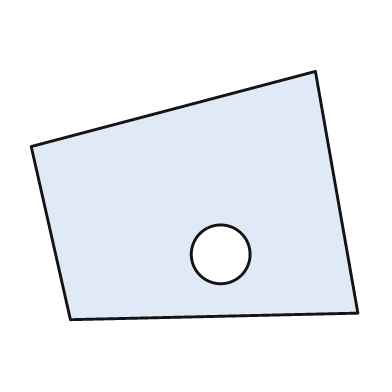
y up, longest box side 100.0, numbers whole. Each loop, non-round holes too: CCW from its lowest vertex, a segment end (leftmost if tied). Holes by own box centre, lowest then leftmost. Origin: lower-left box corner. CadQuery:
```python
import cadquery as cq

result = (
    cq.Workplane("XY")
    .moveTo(12.0, 0.0)
    .lineTo(100.0, 2.0)
    .lineTo(87.0, 76.0)
    .lineTo(0.0, 53.0)
    .close()
    .moveTo(58.0, 20.0)
    .circle(9.0)
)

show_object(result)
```